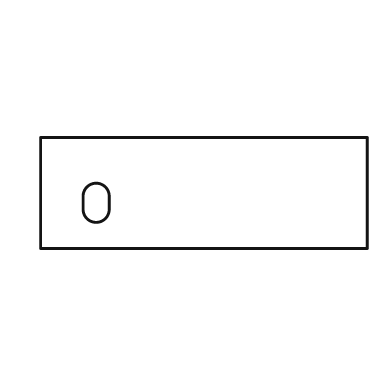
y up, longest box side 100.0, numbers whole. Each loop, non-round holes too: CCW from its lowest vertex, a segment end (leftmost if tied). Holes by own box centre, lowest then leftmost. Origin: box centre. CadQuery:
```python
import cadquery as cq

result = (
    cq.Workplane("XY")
    .moveTo(-50.0, -17.0)
    .lineTo(50.0, -17.0)
    .lineTo(50.0, 17.0)
    .lineTo(-50.0, 17.0)
    .close()
    .moveTo(-37.0, -5.0)
    .threePointArc((-33.0, -9.0), (-29.0, -5.0))
    .lineTo(-29.0, -1.0)
    .threePointArc((-33.0, 3.0), (-37.0, -1.0))
    .close()
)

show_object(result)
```